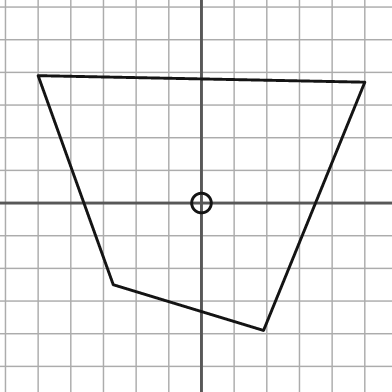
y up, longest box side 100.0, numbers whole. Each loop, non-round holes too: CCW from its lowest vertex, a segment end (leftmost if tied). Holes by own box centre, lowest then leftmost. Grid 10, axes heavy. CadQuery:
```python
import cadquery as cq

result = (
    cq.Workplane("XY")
    .moveTo(19.0, -39.0)
    .lineTo(50.0, 37.0)
    .lineTo(-50.0, 39.0)
    .lineTo(-27.0, -25.0)
    .close()
    .moveTo(0.0, 0.0)
    .circle(3.0)
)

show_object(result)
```